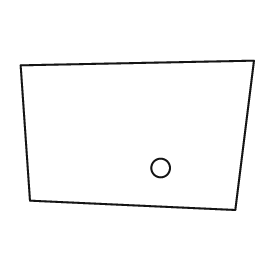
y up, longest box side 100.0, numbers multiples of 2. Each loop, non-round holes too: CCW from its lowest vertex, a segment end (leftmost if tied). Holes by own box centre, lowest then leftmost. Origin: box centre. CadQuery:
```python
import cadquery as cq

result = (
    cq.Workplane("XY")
    .moveTo(42.0, -32.0)
    .lineTo(50.0, 32.0)
    .lineTo(-50.0, 30.0)
    .lineTo(-46.0, -28.0)
    .close()
    .moveTo(10.0, -14.0)
    .circle(4.0)
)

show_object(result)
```